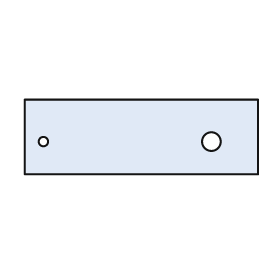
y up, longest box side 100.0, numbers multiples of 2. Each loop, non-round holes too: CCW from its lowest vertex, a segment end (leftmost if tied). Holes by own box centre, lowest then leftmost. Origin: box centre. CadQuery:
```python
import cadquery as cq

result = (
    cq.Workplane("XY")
    .moveTo(-50.0, -16.0)
    .lineTo(50.0, -16.0)
    .lineTo(50.0, 16.0)
    .lineTo(-50.0, 16.0)
    .close()
    .moveTo(-42.0, -2.0)
    .circle(2.0)
    .moveTo(30.0, -2.0)
    .circle(4.0)
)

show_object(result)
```